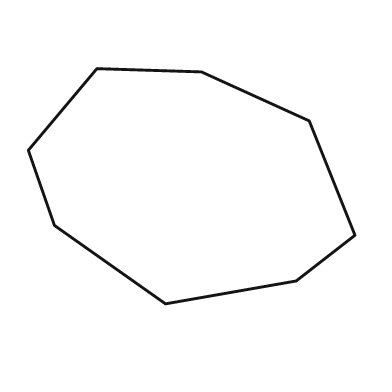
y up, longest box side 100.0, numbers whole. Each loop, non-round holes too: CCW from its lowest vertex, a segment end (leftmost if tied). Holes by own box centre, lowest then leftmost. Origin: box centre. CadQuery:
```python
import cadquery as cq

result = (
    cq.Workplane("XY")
    .moveTo(-8.0, -36.0)
    .lineTo(32.0, -29.0)
    .lineTo(50.0, -15.0)
    .lineTo(36.0, 20.0)
    .lineTo(3.0, 35.0)
    .lineTo(-29.0, 36.0)
    .lineTo(-50.0, 11.0)
    .lineTo(-42.0, -12.0)
    .close()
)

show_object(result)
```